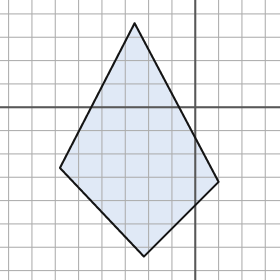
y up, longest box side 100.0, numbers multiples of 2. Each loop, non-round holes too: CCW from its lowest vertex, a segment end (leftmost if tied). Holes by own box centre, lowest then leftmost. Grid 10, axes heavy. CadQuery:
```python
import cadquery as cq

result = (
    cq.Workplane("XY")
    .moveTo(-22.0, -64.0)
    .lineTo(10.0, -32.0)
    .lineTo(-26.0, 36.0)
    .lineTo(-58.0, -26.0)
    .close()
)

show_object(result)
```